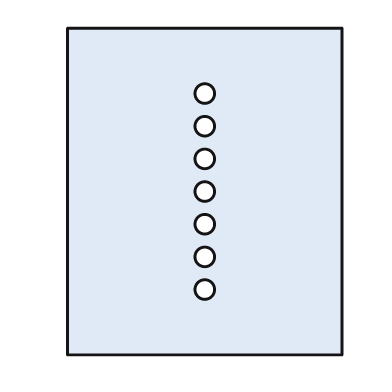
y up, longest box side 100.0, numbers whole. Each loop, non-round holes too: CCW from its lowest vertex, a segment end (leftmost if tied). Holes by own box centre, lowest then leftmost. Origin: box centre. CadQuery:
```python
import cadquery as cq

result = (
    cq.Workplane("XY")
    .moveTo(-42.0, -50.0)
    .lineTo(42.0, -50.0)
    .lineTo(42.0, 50.0)
    .lineTo(-42.0, 50.0)
    .close()
    .moveTo(0.0, -30.0)
    .circle(3.0)
    .moveTo(0.0, -20.0)
    .circle(3.0)
    .moveTo(0.0, -10.0)
    .circle(3.0)
    .moveTo(0.0, 0.0)
    .circle(3.0)
    .moveTo(0.0, 10.0)
    .circle(3.0)
    .moveTo(0.0, 20.0)
    .circle(3.0)
    .moveTo(0.0, 30.0)
    .circle(3.0)
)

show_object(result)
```